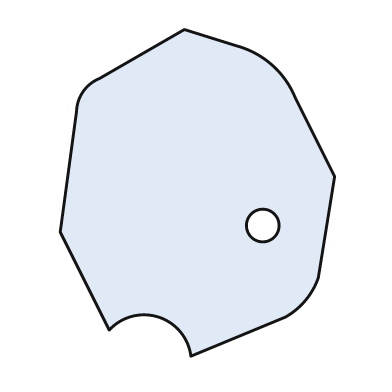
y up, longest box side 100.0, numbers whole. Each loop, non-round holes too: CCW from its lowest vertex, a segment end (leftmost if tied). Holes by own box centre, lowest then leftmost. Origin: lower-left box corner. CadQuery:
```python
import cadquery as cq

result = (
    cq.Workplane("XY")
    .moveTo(40.0, 0.0)
    .lineTo(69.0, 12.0)
    .threePointArc((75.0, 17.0), (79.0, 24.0))
    .lineTo(84.0, 55.0)
    .lineTo(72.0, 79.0)
    .threePointArc((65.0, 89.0), (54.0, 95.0))
    .lineTo(38.0, 100.0)
    .lineTo(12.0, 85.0)
    .threePointArc((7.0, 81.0), (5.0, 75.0))
    .lineTo(0.0, 38.0)
    .lineTo(15.0, 8.0)
    .threePointArc((30.0, 12.0), (40.0, 0.0))
    .close()
    .moveTo(62.0, 40.0)
    .circle(5.0)
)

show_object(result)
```